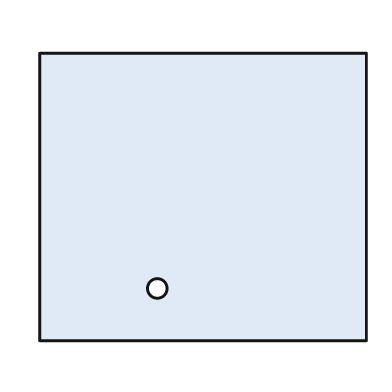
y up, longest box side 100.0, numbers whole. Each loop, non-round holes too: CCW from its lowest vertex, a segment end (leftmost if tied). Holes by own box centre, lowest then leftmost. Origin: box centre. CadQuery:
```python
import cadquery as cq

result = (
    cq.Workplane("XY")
    .moveTo(-50.0, -44.0)
    .lineTo(50.0, -44.0)
    .lineTo(50.0, 44.0)
    .lineTo(-50.0, 44.0)
    .close()
    .moveTo(-14.0, -28.0)
    .circle(3.0)
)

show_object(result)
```